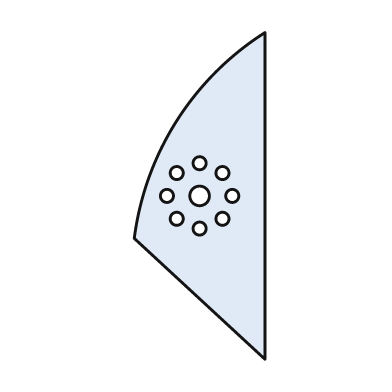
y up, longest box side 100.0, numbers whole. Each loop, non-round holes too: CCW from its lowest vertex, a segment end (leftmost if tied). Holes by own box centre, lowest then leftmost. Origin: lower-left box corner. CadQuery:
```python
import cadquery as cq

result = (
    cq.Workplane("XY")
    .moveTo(40.0, 0.0)
    .lineTo(40.0, 100.0)
    .threePointArc((13.0, 73.0), (0.0, 37.0))
    .close()
    .moveTo(20.0, 40.0)
    .circle(2.0)
    .moveTo(13.0, 43.0)
    .circle(2.0)
    .moveTo(27.0, 43.0)
    .circle(2.0)
    .moveTo(10.0, 50.0)
    .circle(2.0)
    .moveTo(20.0, 50.0)
    .circle(3.0)
    .moveTo(30.0, 50.0)
    .circle(2.0)
    .moveTo(13.0, 57.0)
    .circle(2.0)
    .moveTo(27.0, 57.0)
    .circle(2.0)
    .moveTo(20.0, 60.0)
    .circle(2.0)
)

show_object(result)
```